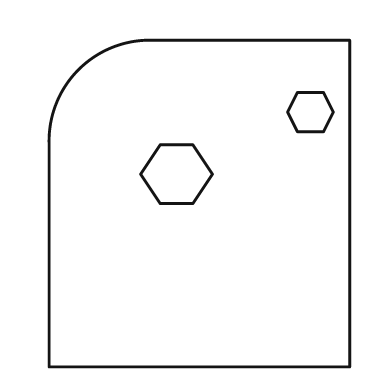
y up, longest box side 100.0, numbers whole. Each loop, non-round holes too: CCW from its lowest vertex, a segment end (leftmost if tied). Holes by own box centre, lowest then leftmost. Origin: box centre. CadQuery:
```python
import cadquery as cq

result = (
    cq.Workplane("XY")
    .moveTo(-46.0, -50.0)
    .lineTo(46.0, -50.0)
    .lineTo(46.0, 50.0)
    .lineTo(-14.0, 50.0)
    .threePointArc((-37.0, 41.0), (-46.0, 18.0))
    .close()
    .moveTo(-12.0, 0.0)
    .lineTo(-2.0, 0.0)
    .lineTo(4.0, 9.0)
    .lineTo(-2.0, 18.0)
    .lineTo(-12.0, 18.0)
    .lineTo(-18.0, 9.0)
    .close()
    .moveTo(30.0, 22.0)
    .lineTo(38.0, 22.0)
    .lineTo(41.0, 28.0)
    .lineTo(38.0, 34.0)
    .lineTo(30.0, 34.0)
    .lineTo(27.0, 28.0)
    .close()
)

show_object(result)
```